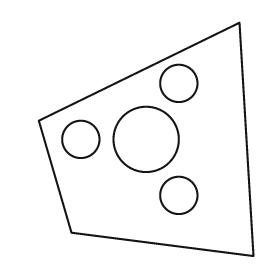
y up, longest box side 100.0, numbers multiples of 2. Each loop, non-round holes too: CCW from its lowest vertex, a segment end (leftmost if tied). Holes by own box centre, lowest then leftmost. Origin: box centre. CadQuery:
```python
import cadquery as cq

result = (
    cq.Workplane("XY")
    .moveTo(46.0, -50.0)
    .lineTo(40.0, 50.0)
    .lineTo(-46.0, 8.0)
    .lineTo(-32.0, -40.0)
    .close()
    .moveTo(14.0, -24.0)
    .circle(8.0)
    .moveTo(-28.0, 0.0)
    .circle(8.0)
    .moveTo(0.0, 0.0)
    .circle(14.0)
    .moveTo(14.0, 24.0)
    .circle(8.0)
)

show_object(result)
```